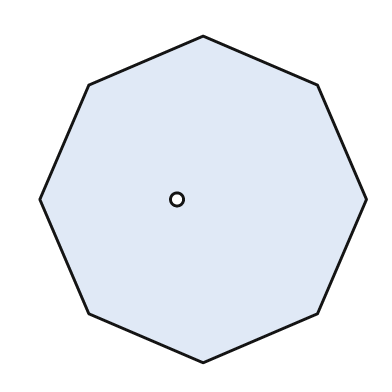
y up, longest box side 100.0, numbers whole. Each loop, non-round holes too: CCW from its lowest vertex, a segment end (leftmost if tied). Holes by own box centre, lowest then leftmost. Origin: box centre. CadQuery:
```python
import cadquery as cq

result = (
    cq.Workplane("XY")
    .moveTo(0.0, -50.0)
    .lineTo(35.0, -35.0)
    .lineTo(50.0, 0.0)
    .lineTo(35.0, 35.0)
    .lineTo(0.0, 50.0)
    .lineTo(-35.0, 35.0)
    .lineTo(-50.0, 0.0)
    .lineTo(-35.0, -35.0)
    .close()
    .moveTo(-8.0, 0.0)
    .circle(2.0)
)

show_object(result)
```